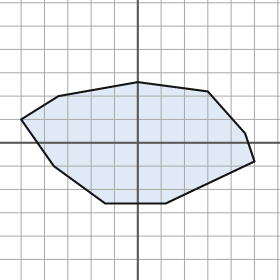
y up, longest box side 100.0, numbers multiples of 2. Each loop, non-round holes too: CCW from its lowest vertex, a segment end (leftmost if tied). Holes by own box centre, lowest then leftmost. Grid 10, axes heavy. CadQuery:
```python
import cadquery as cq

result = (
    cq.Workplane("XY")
    .moveTo(-14.0, -26.0)
    .lineTo(12.0, -26.0)
    .lineTo(50.0, -8.0)
    .lineTo(46.0, 4.0)
    .lineTo(30.0, 22.0)
    .lineTo(0.0, 26.0)
    .lineTo(-34.0, 20.0)
    .lineTo(-50.0, 10.0)
    .lineTo(-36.0, -10.0)
    .close()
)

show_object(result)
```